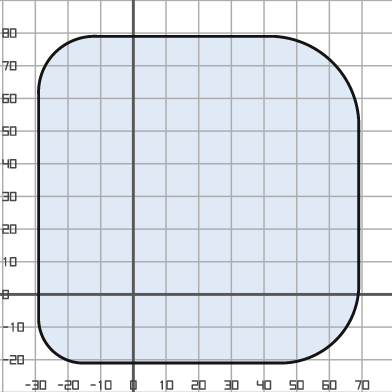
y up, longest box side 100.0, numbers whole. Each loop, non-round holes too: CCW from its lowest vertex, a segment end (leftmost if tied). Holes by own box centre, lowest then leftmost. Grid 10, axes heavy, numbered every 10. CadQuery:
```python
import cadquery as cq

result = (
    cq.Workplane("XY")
    .moveTo(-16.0, -21.0)
    .lineTo(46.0, -21.0)
    .threePointArc((62.0, -14.0), (69.0, 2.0))
    .lineTo(69.0, 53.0)
    .threePointArc((61.0, 71.0), (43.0, 79.0))
    .lineTo(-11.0, 79.0)
    .threePointArc((-24.0, 74.0), (-29.0, 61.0))
    .lineTo(-29.0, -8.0)
    .threePointArc((-25.0, -17.0), (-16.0, -21.0))
    .close()
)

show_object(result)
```